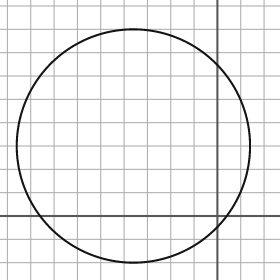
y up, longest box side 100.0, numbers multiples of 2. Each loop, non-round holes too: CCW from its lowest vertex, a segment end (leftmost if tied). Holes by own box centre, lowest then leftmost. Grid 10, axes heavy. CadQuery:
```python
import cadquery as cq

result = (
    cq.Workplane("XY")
    .moveTo(-36.0, 30.0)
    .circle(50.0)
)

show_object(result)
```